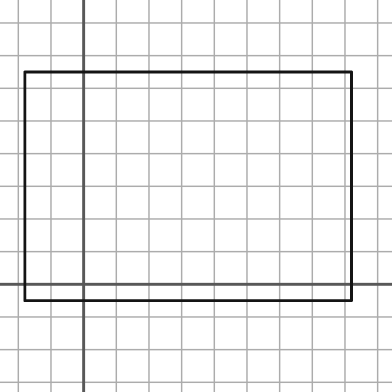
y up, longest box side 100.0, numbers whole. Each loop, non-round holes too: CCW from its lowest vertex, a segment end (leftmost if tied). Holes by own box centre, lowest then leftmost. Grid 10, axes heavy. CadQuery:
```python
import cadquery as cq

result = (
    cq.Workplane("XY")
    .moveTo(-18.0, -5.0)
    .lineTo(82.0, -5.0)
    .lineTo(82.0, 65.0)
    .lineTo(-18.0, 65.0)
    .close()
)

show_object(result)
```